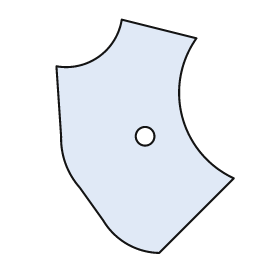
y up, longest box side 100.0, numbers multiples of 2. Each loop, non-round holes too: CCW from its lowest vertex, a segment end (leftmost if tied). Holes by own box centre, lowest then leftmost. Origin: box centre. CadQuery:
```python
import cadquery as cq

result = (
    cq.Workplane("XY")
    .moveTo(6.0, -50.0)
    .lineTo(38.0, -18.0)
    .threePointArc((16.0, 8.0), (22.0, 42.0))
    .lineTo(-10.0, 50.0)
    .threePointArc((-20.0, 34.0), (-38.0, 30.0))
    .lineTo(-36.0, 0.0)
    .threePointArc((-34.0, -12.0), (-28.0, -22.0))
    .lineTo(-18.0, -36.0)
    .threePointArc((-8.0, -46.0), (6.0, -50.0))
    .close()
    .moveTo(0.0, 0.0)
    .circle(4.0)
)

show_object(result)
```